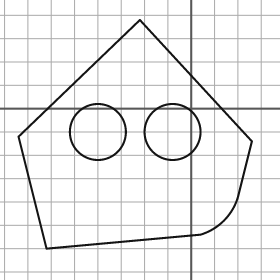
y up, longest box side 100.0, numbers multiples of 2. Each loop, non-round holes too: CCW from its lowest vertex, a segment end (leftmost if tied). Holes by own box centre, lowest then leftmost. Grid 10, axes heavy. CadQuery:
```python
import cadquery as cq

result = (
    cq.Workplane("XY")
    .moveTo(-62.0, -60.0)
    .lineTo(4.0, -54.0)
    .threePointArc((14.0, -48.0), (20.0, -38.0))
    .lineTo(26.0, -14.0)
    .lineTo(-22.0, 38.0)
    .lineTo(-74.0, -12.0)
    .close()
    .moveTo(-40.0, -10.0)
    .circle(12.0)
    .moveTo(-8.0, -10.0)
    .circle(12.0)
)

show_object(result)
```